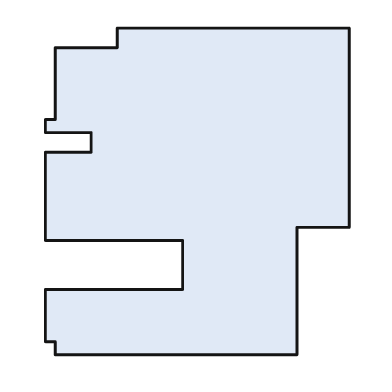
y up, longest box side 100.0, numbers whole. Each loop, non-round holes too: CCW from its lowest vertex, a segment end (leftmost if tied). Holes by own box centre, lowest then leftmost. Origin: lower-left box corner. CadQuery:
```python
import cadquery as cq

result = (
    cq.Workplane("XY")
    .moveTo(3.0, 0.0)
    .lineTo(77.0, 0.0)
    .lineTo(77.0, 39.0)
    .lineTo(93.0, 39.0)
    .lineTo(93.0, 100.0)
    .lineTo(22.0, 100.0)
    .lineTo(22.0, 94.0)
    .lineTo(3.0, 94.0)
    .lineTo(3.0, 72.0)
    .lineTo(0.0, 72.0)
    .lineTo(0.0, 68.0)
    .lineTo(14.0, 68.0)
    .lineTo(14.0, 62.0)
    .lineTo(0.0, 62.0)
    .lineTo(0.0, 35.0)
    .lineTo(42.0, 35.0)
    .lineTo(42.0, 20.0)
    .lineTo(0.0, 20.0)
    .lineTo(0.0, 4.0)
    .lineTo(3.0, 4.0)
    .close()
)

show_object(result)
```